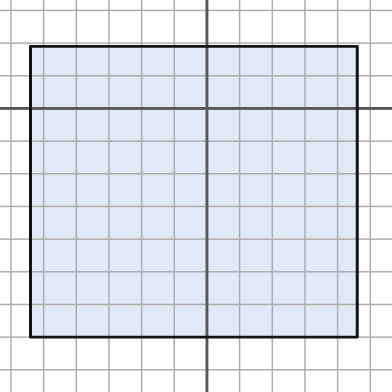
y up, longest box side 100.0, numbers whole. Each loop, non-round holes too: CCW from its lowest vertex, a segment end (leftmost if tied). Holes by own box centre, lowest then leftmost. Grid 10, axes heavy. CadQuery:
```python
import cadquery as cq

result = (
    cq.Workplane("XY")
    .moveTo(-54.0, -70.0)
    .lineTo(46.0, -70.0)
    .lineTo(46.0, 19.0)
    .lineTo(-54.0, 19.0)
    .close()
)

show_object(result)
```